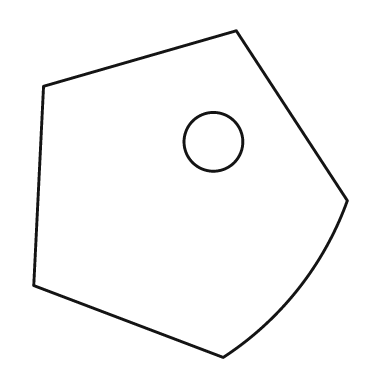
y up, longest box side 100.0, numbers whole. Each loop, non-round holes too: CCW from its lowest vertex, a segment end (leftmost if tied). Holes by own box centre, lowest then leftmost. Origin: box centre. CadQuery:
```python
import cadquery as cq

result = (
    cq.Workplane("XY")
    .moveTo(10.0, -50.0)
    .threePointArc((33.0, -29.0), (48.0, -2.0))
    .lineTo(14.0, 50.0)
    .lineTo(-45.0, 33.0)
    .lineTo(-48.0, -28.0)
    .close()
    .moveTo(7.0, 16.0)
    .circle(9.0)
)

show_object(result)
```